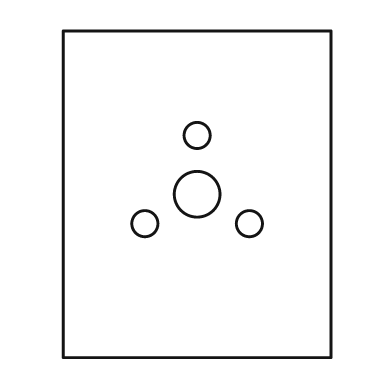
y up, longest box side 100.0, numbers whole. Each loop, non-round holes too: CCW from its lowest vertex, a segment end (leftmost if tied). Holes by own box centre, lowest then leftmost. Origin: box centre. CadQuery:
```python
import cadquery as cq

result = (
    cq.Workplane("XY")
    .moveTo(-41.0, -50.0)
    .lineTo(41.0, -50.0)
    .lineTo(41.0, 50.0)
    .lineTo(-41.0, 50.0)
    .close()
    .moveTo(-16.0, -9.0)
    .circle(4.0)
    .moveTo(16.0, -9.0)
    .circle(4.0)
    .moveTo(0.0, 0.0)
    .circle(7.0)
    .moveTo(0.0, 18.0)
    .circle(4.0)
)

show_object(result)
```